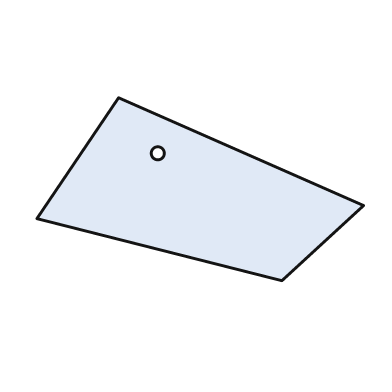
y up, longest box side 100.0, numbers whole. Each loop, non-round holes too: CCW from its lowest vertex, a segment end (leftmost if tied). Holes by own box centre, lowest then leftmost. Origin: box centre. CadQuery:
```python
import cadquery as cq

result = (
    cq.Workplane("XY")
    .moveTo(25.0, -28.0)
    .lineTo(50.0, -5.0)
    .lineTo(-25.0, 28.0)
    .lineTo(-50.0, -9.0)
    .close()
    .moveTo(-13.0, 11.0)
    .circle(2.0)
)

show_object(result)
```